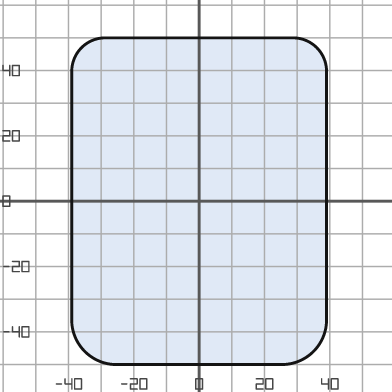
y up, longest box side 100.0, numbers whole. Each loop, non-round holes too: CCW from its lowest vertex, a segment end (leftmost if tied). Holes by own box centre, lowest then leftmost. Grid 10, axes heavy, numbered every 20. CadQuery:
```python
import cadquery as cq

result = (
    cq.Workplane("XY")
    .moveTo(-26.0, -50.0)
    .lineTo(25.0, -50.0)
    .threePointArc((35.0, -46.0), (39.0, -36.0))
    .lineTo(39.0, 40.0)
    .threePointArc((36.0, 47.0), (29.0, 50.0))
    .lineTo(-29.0, 50.0)
    .threePointArc((-36.0, 47.0), (-39.0, 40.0))
    .lineTo(-39.0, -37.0)
    .threePointArc((-35.0, -46.0), (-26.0, -50.0))
    .close()
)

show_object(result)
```